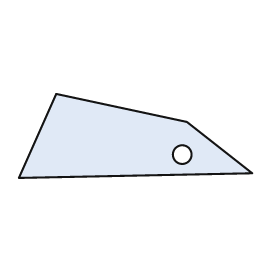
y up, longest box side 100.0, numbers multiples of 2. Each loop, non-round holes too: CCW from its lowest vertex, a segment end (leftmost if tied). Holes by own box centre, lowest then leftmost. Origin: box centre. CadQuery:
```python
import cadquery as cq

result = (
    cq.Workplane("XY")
    .moveTo(-50.0, -18.0)
    .lineTo(50.0, -16.0)
    .lineTo(22.0, 6.0)
    .lineTo(-34.0, 18.0)
    .close()
    .moveTo(20.0, -8.0)
    .circle(4.0)
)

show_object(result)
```